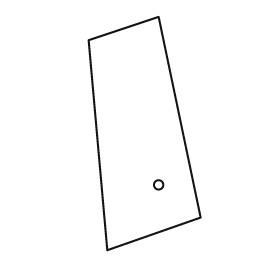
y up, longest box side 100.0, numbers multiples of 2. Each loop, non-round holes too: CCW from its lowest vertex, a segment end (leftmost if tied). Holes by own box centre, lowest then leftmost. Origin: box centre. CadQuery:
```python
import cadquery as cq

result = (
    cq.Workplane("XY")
    .moveTo(-16.0, -50.0)
    .lineTo(24.0, -36.0)
    .lineTo(6.0, 50.0)
    .lineTo(-24.0, 40.0)
    .close()
    .moveTo(6.0, -22.0)
    .circle(2.0)
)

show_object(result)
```